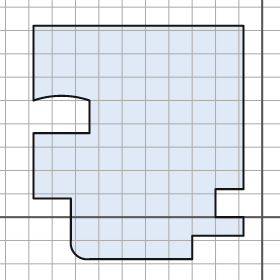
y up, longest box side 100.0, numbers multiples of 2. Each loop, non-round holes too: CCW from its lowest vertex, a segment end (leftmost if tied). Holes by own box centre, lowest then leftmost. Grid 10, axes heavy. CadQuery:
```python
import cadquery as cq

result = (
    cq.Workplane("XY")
    .moveTo(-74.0, -18.0)
    .lineTo(-30.0, -18.0)
    .lineTo(-30.0, -8.0)
    .lineTo(-8.0, -8.0)
    .lineTo(-8.0, 0.0)
    .lineTo(-20.0, 0.0)
    .lineTo(-20.0, 12.0)
    .lineTo(-8.0, 12.0)
    .lineTo(-8.0, 82.0)
    .lineTo(-98.0, 82.0)
    .lineTo(-98.0, 50.0)
    .threePointArc((-86.0, 52.0), (-74.0, 50.0))
    .lineTo(-74.0, 36.0)
    .lineTo(-98.0, 36.0)
    .lineTo(-98.0, 8.0)
    .lineTo(-82.0, 8.0)
    .lineTo(-82.0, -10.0)
    .threePointArc((-80.0, -16.0), (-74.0, -18.0))
    .close()
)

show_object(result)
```